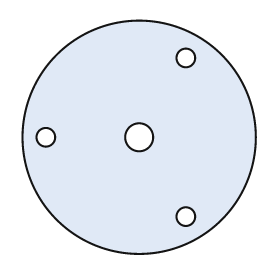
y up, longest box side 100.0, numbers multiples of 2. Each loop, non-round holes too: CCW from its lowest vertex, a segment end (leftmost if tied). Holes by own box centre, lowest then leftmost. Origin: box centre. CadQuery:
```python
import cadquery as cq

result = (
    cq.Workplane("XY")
    .moveTo(0.0, 0.0)
    .circle(50.0)
    .moveTo(20.0, -34.0)
    .circle(4.0)
    .moveTo(-40.0, 0.0)
    .circle(4.0)
    .moveTo(0.0, 0.0)
    .circle(6.0)
    .moveTo(20.0, 34.0)
    .circle(4.0)
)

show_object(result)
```